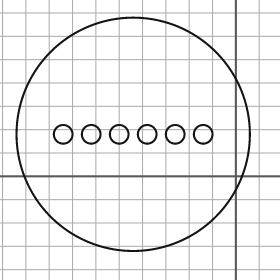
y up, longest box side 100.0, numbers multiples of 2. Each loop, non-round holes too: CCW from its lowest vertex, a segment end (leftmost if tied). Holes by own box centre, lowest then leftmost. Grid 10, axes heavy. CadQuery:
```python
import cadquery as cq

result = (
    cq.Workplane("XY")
    .moveTo(-44.0, 18.0)
    .circle(50.0)
    .moveTo(-74.0, 18.0)
    .circle(4.0)
    .moveTo(-62.0, 18.0)
    .circle(4.0)
    .moveTo(-50.0, 18.0)
    .circle(4.0)
    .moveTo(-38.0, 18.0)
    .circle(4.0)
    .moveTo(-26.0, 18.0)
    .circle(4.0)
    .moveTo(-14.0, 18.0)
    .circle(4.0)
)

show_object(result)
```